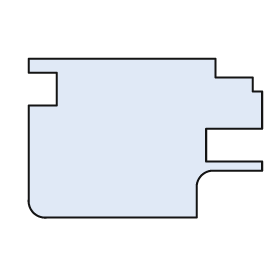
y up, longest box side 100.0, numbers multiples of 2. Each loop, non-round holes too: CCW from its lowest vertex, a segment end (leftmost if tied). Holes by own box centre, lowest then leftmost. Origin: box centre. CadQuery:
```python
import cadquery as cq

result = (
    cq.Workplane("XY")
    .moveTo(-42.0, -34.0)
    .lineTo(22.0, -34.0)
    .lineTo(22.0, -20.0)
    .threePointArc((24.0, -16.0), (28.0, -14.0))
    .lineTo(50.0, -14.0)
    .lineTo(50.0, -10.0)
    .lineTo(26.0, -10.0)
    .lineTo(26.0, 4.0)
    .lineTo(50.0, 4.0)
    .lineTo(50.0, 20.0)
    .lineTo(46.0, 20.0)
    .lineTo(46.0, 26.0)
    .lineTo(30.0, 26.0)
    .lineTo(30.0, 34.0)
    .lineTo(-50.0, 34.0)
    .lineTo(-50.0, 28.0)
    .lineTo(-38.0, 28.0)
    .lineTo(-38.0, 14.0)
    .lineTo(-50.0, 14.0)
    .lineTo(-50.0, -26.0)
    .threePointArc((-48.0, -32.0), (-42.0, -34.0))
    .close()
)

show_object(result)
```